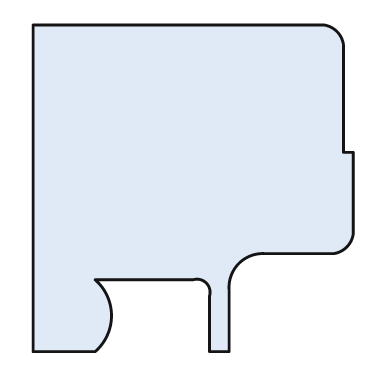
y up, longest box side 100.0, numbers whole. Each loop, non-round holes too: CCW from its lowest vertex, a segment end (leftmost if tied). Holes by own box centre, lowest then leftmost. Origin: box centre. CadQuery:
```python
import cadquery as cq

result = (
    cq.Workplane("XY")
    .moveTo(-49.0, -50.0)
    .lineTo(-30.0, -50.0)
    .threePointArc((-25.0, -39.0), (-30.0, -28.0))
    .lineTo(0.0, -28.0)
    .threePointArc((4.0, -29.0), (5.0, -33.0))
    .lineTo(5.0, -50.0)
    .lineTo(11.0, -50.0)
    .lineTo(11.0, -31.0)
    .threePointArc((14.0, -23.0), (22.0, -20.0))
    .lineTo(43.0, -20.0)
    .threePointArc((47.0, -18.0), (49.0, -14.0))
    .lineTo(49.0, 11.0)
    .lineTo(46.0, 11.0)
    .lineTo(46.0, 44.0)
    .threePointArc((44.0, 48.0), (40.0, 50.0))
    .lineTo(-49.0, 50.0)
    .close()
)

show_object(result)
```